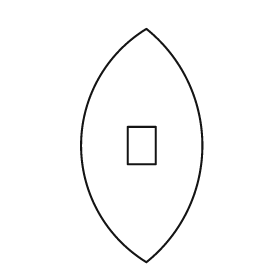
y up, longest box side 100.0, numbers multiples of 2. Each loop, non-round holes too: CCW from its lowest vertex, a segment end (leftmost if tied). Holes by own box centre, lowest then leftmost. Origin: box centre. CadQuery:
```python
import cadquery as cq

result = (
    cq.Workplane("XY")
    .moveTo(2.0, -50.0)
    .threePointArc((26.0, 0.0), (2.0, 50.0))
    .threePointArc((-26.0, 0.0), (2.0, -50.0))
    .close()
    .moveTo(-6.0, -8.0)
    .lineTo(6.0, -8.0)
    .lineTo(6.0, 8.0)
    .lineTo(-6.0, 8.0)
    .close()
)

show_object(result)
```